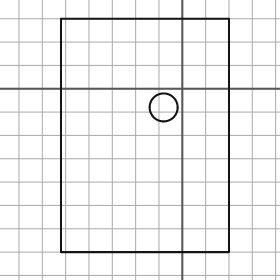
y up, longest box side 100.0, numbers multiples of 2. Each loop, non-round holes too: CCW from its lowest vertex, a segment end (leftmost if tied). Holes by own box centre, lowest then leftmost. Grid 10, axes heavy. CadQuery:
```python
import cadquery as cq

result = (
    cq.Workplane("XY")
    .moveTo(-52.0, -70.0)
    .lineTo(20.0, -70.0)
    .lineTo(20.0, 30.0)
    .lineTo(-52.0, 30.0)
    .close()
    .moveTo(-8.0, -8.0)
    .circle(6.0)
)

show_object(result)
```